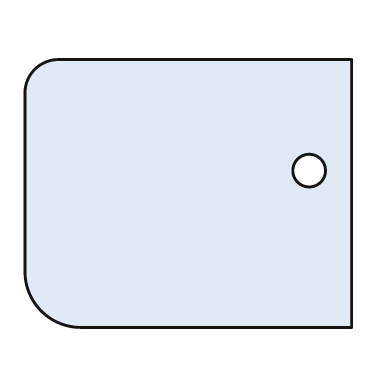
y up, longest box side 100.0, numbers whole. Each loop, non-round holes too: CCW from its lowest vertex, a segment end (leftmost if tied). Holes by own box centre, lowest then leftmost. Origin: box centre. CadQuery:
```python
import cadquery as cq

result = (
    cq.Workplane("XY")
    .moveTo(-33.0, -41.0)
    .lineTo(50.0, -41.0)
    .lineTo(50.0, 41.0)
    .lineTo(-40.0, 41.0)
    .threePointArc((-47.0, 38.0), (-50.0, 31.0))
    .lineTo(-50.0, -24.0)
    .threePointArc((-45.0, -36.0), (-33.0, -41.0))
    .close()
    .moveTo(37.0, 7.0)
    .circle(5.0)
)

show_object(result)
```